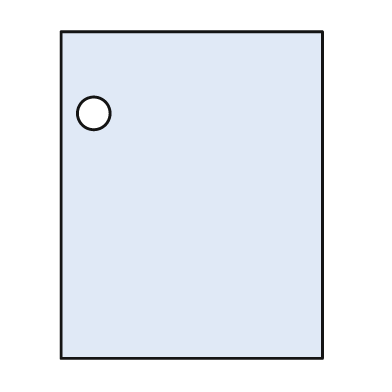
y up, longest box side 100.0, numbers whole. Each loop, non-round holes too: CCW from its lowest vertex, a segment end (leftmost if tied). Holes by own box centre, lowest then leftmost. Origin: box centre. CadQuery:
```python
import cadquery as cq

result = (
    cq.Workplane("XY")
    .moveTo(-40.0, -50.0)
    .lineTo(40.0, -50.0)
    .lineTo(40.0, 50.0)
    .lineTo(-40.0, 50.0)
    .close()
    .moveTo(-30.0, 25.0)
    .circle(5.0)
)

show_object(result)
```